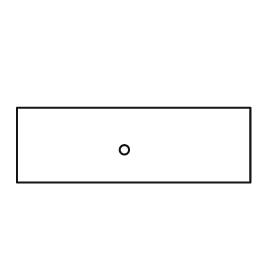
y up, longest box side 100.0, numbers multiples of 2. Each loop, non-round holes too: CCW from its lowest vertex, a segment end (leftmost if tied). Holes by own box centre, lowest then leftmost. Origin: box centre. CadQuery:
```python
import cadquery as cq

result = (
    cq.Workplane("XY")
    .moveTo(-50.0, -16.0)
    .lineTo(50.0, -16.0)
    .lineTo(50.0, 16.0)
    .lineTo(-50.0, 16.0)
    .close()
    .moveTo(-4.0, -2.0)
    .circle(2.0)
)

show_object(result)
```